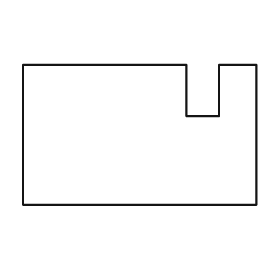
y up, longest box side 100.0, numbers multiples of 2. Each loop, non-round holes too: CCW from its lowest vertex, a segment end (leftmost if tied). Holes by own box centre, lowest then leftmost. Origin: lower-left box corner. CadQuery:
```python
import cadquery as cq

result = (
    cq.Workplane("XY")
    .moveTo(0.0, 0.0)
    .lineTo(100.0, 0.0)
    .lineTo(100.0, 60.0)
    .lineTo(84.0, 60.0)
    .lineTo(84.0, 38.0)
    .lineTo(70.0, 38.0)
    .lineTo(70.0, 60.0)
    .lineTo(0.0, 60.0)
    .close()
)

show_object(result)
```